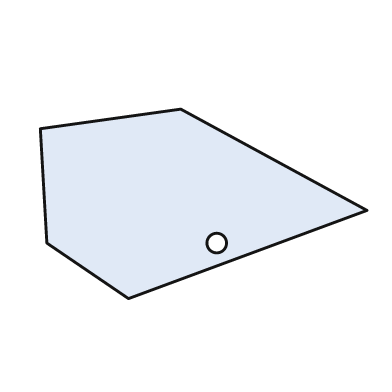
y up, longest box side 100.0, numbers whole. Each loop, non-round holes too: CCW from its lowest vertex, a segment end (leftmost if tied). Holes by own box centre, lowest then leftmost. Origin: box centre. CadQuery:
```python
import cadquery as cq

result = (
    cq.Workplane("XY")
    .moveTo(-23.0, -29.0)
    .lineTo(50.0, -2.0)
    .lineTo(-7.0, 29.0)
    .lineTo(-50.0, 23.0)
    .lineTo(-48.0, -12.0)
    .close()
    .moveTo(4.0, -12.0)
    .circle(3.0)
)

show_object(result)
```